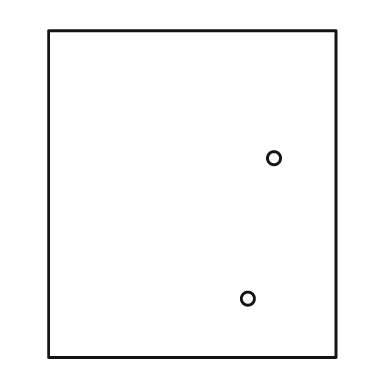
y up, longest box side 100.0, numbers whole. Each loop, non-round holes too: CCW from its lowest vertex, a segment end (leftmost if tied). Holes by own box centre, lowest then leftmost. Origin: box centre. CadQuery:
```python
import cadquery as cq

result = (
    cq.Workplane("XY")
    .moveTo(-44.0, -50.0)
    .lineTo(44.0, -50.0)
    .lineTo(44.0, 50.0)
    .lineTo(-44.0, 50.0)
    .close()
    .moveTo(17.0, -32.0)
    .circle(2.0)
    .moveTo(25.0, 11.0)
    .circle(2.0)
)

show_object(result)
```